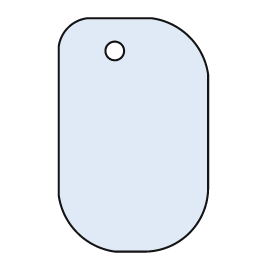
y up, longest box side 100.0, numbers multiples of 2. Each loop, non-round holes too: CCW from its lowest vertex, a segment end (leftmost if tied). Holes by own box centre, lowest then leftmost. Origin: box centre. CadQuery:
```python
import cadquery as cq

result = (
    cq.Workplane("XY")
    .moveTo(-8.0, -50.0)
    .lineTo(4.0, -50.0)
    .threePointArc((24.0, -42.0), (32.0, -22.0))
    .lineTo(32.0, 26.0)
    .threePointArc((24.0, 42.0), (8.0, 50.0))
    .lineTo(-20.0, 50.0)
    .threePointArc((-28.0, 46.0), (-32.0, 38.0))
    .lineTo(-32.0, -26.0)
    .threePointArc((-24.0, -42.0), (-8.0, -50.0))
    .close()
    .moveTo(-8.0, 36.0)
    .circle(4.0)
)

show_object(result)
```